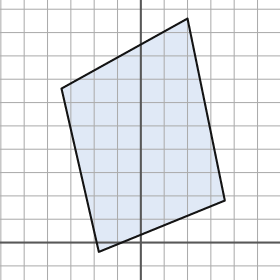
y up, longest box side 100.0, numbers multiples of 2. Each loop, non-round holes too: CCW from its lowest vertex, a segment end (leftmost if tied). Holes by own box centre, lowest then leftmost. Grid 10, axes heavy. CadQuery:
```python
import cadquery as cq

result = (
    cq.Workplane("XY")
    .moveTo(-18.0, -4.0)
    .lineTo(36.0, 18.0)
    .lineTo(20.0, 96.0)
    .lineTo(-34.0, 66.0)
    .close()
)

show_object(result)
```